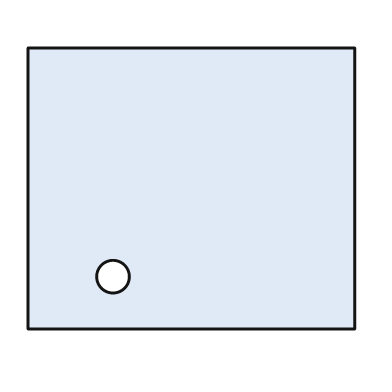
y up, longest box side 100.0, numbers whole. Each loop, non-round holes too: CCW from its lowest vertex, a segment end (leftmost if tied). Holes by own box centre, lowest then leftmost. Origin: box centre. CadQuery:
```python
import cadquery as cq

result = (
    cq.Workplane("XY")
    .moveTo(-50.0, -43.0)
    .lineTo(50.0, -43.0)
    .lineTo(50.0, 43.0)
    .lineTo(-50.0, 43.0)
    .close()
    .moveTo(-24.0, -27.0)
    .circle(5.0)
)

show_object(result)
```